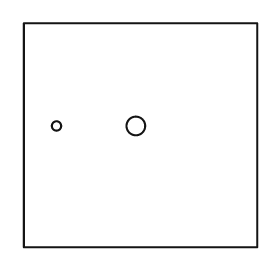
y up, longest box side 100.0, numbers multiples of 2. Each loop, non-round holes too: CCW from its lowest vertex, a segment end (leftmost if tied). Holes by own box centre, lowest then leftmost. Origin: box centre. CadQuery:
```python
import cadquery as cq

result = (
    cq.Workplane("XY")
    .moveTo(-50.0, -48.0)
    .lineTo(50.0, -48.0)
    .lineTo(50.0, 48.0)
    .lineTo(-50.0, 48.0)
    .close()
    .moveTo(-36.0, 4.0)
    .circle(2.0)
    .moveTo(-2.0, 4.0)
    .circle(4.0)
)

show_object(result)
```